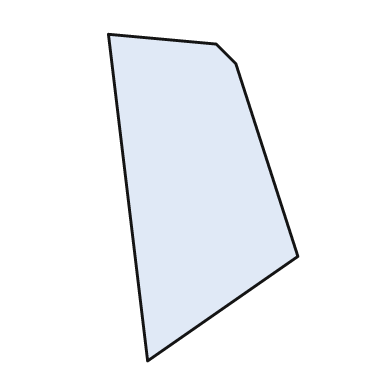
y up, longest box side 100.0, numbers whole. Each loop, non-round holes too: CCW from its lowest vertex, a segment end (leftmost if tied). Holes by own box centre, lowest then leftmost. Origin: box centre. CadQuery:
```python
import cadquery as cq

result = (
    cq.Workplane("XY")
    .moveTo(-17.0, -50.0)
    .lineTo(29.0, -18.0)
    .lineTo(10.0, 41.0)
    .lineTo(4.0, 47.0)
    .lineTo(-29.0, 50.0)
    .close()
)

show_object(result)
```